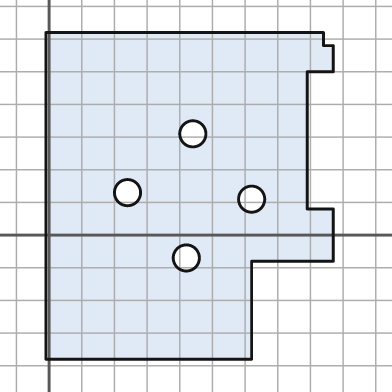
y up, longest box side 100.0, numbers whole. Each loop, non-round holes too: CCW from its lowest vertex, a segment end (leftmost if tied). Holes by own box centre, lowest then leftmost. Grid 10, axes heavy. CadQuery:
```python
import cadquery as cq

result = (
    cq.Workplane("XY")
    .moveTo(-1.0, -38.0)
    .lineTo(62.0, -38.0)
    .lineTo(62.0, -8.0)
    .lineTo(87.0, -8.0)
    .lineTo(87.0, 8.0)
    .lineTo(79.0, 8.0)
    .lineTo(79.0, 50.0)
    .lineTo(87.0, 50.0)
    .lineTo(87.0, 58.0)
    .lineTo(84.0, 58.0)
    .lineTo(84.0, 62.0)
    .lineTo(-1.0, 62.0)
    .close()
    .moveTo(42.0, -7.0)
    .circle(4.0)
    .moveTo(62.0, 11.0)
    .circle(4.0)
    .moveTo(24.0, 13.0)
    .circle(4.0)
    .moveTo(44.0, 31.0)
    .circle(4.0)
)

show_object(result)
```